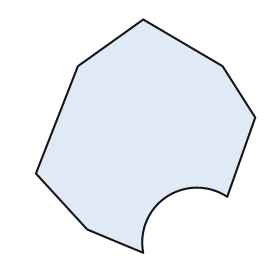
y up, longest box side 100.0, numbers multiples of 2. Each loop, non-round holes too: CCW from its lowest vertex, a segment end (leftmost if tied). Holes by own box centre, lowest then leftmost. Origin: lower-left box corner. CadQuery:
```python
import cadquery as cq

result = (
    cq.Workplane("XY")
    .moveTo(46.0, 0.0)
    .threePointArc((56.0, 24.0), (82.0, 24.0))
    .lineTo(94.0, 58.0)
    .lineTo(80.0, 80.0)
    .lineTo(46.0, 100.0)
    .lineTo(18.0, 80.0)
    .lineTo(0.0, 34.0)
    .lineTo(22.0, 10.0)
    .close()
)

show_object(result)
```